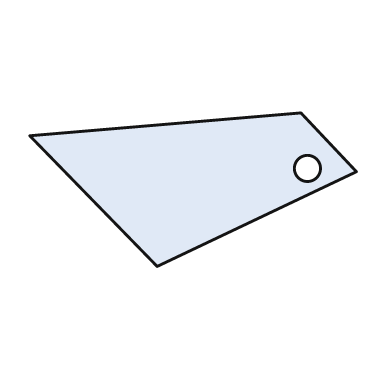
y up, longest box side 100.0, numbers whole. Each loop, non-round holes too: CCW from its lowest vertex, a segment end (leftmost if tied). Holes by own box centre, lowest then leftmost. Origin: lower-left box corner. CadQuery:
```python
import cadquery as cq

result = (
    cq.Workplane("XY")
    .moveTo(39.0, 0.0)
    .lineTo(100.0, 29.0)
    .lineTo(83.0, 47.0)
    .lineTo(0.0, 40.0)
    .close()
    .moveTo(85.0, 30.0)
    .circle(4.0)
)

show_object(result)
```